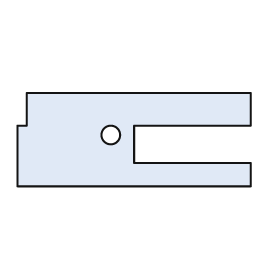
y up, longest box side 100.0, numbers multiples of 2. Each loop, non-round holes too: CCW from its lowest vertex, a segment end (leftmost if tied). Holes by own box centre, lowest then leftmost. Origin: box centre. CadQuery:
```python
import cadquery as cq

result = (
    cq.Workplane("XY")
    .moveTo(-50.0, -20.0)
    .lineTo(50.0, -20.0)
    .lineTo(50.0, -10.0)
    .lineTo(0.0, -10.0)
    .lineTo(0.0, 6.0)
    .lineTo(50.0, 6.0)
    .lineTo(50.0, 20.0)
    .lineTo(-46.0, 20.0)
    .lineTo(-46.0, 6.0)
    .lineTo(-50.0, 6.0)
    .close()
    .moveTo(-10.0, 2.0)
    .circle(4.0)
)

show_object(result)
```